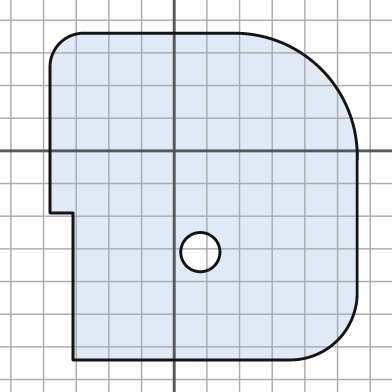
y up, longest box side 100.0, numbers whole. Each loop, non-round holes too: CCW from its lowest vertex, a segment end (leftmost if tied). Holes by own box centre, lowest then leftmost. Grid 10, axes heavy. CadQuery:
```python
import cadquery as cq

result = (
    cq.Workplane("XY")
    .moveTo(-31.0, -64.0)
    .lineTo(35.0, -64.0)
    .threePointArc((50.0, -58.0), (56.0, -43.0))
    .lineTo(56.0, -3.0)
    .threePointArc((45.0, 25.0), (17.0, 36.0))
    .lineTo(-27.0, 36.0)
    .threePointArc((-35.0, 33.0), (-38.0, 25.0))
    .lineTo(-38.0, -19.0)
    .lineTo(-31.0, -19.0)
    .close()
    .moveTo(8.0, -31.0)
    .circle(6.0)
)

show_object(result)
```